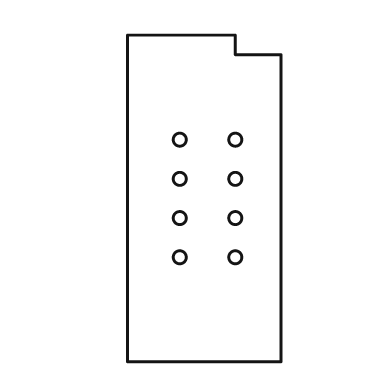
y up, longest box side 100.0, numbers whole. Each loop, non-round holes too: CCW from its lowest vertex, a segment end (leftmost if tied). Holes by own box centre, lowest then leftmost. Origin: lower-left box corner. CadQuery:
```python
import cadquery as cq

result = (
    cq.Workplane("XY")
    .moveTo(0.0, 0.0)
    .lineTo(47.0, 0.0)
    .lineTo(47.0, 94.0)
    .lineTo(33.0, 94.0)
    .lineTo(33.0, 100.0)
    .lineTo(0.0, 100.0)
    .close()
    .moveTo(16.0, 32.0)
    .circle(2.0)
    .moveTo(33.0, 32.0)
    .circle(2.0)
    .moveTo(16.0, 44.0)
    .circle(2.0)
    .moveTo(33.0, 44.0)
    .circle(2.0)
    .moveTo(16.0, 56.0)
    .circle(2.0)
    .moveTo(33.0, 56.0)
    .circle(2.0)
    .moveTo(16.0, 68.0)
    .circle(2.0)
    .moveTo(33.0, 68.0)
    .circle(2.0)
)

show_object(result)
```